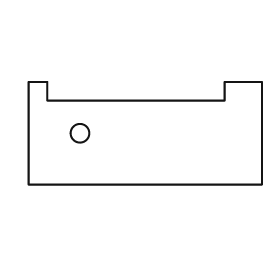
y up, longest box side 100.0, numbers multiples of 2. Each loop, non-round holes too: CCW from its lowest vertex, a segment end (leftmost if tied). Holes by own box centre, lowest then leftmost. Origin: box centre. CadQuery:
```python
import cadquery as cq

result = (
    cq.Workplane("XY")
    .moveTo(-50.0, -22.0)
    .lineTo(50.0, -22.0)
    .lineTo(50.0, 22.0)
    .lineTo(34.0, 22.0)
    .lineTo(34.0, 14.0)
    .lineTo(-42.0, 14.0)
    .lineTo(-42.0, 22.0)
    .lineTo(-50.0, 22.0)
    .close()
    .moveTo(-28.0, 0.0)
    .circle(4.0)
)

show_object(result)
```